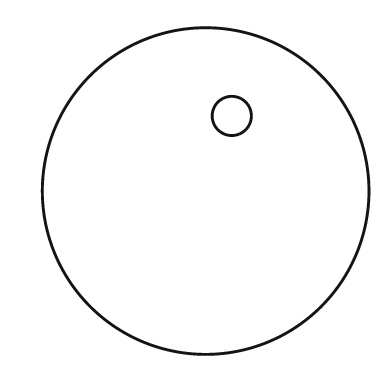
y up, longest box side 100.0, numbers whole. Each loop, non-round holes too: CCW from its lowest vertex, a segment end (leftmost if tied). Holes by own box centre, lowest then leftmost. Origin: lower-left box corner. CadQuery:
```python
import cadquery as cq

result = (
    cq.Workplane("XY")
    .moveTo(50.0, 50.0)
    .circle(50.0)
    .moveTo(58.0, 73.0)
    .circle(6.0)
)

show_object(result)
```